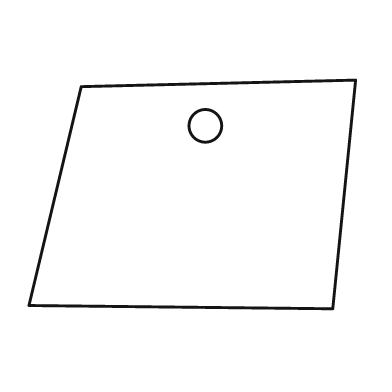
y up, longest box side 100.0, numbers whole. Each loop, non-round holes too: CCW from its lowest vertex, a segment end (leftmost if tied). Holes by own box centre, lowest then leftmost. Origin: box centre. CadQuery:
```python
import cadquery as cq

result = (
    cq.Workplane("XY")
    .moveTo(43.0, -35.0)
    .lineTo(50.0, 35.0)
    .lineTo(-34.0, 33.0)
    .lineTo(-50.0, -34.0)
    .close()
    .moveTo(4.0, 21.0)
    .circle(5.0)
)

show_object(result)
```